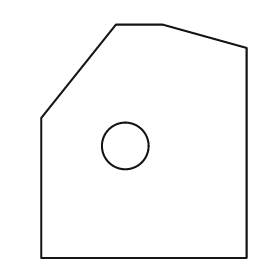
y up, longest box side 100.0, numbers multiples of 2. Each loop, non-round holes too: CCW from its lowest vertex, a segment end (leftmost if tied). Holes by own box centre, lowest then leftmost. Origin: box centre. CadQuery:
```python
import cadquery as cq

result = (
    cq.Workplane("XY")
    .moveTo(-44.0, -50.0)
    .lineTo(44.0, -50.0)
    .lineTo(44.0, 40.0)
    .lineTo(8.0, 50.0)
    .lineTo(-12.0, 50.0)
    .lineTo(-44.0, 10.0)
    .close()
    .moveTo(-8.0, -2.0)
    .circle(10.0)
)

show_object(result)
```